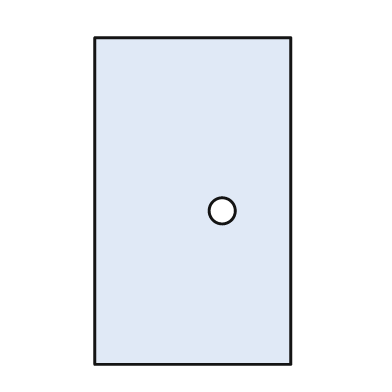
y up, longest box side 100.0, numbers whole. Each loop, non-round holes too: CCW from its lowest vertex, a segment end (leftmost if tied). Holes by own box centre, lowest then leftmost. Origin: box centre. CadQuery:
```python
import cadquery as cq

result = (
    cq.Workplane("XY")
    .moveTo(-30.0, -50.0)
    .lineTo(30.0, -50.0)
    .lineTo(30.0, 50.0)
    .lineTo(-30.0, 50.0)
    .close()
    .moveTo(9.0, -3.0)
    .circle(4.0)
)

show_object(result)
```